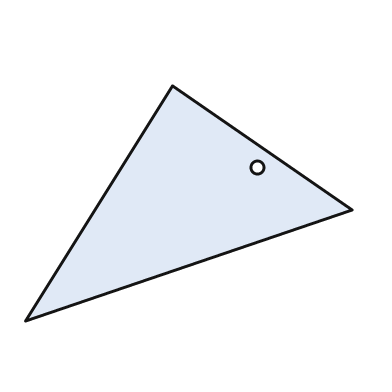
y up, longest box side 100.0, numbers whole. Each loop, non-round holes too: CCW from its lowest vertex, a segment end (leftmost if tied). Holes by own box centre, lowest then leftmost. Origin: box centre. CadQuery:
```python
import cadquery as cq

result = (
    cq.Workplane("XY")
    .moveTo(-50.0, -36.0)
    .lineTo(50.0, -2.0)
    .lineTo(-5.0, 36.0)
    .close()
    .moveTo(21.0, 11.0)
    .circle(2.0)
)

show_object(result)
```